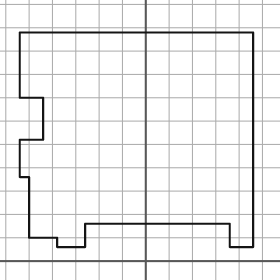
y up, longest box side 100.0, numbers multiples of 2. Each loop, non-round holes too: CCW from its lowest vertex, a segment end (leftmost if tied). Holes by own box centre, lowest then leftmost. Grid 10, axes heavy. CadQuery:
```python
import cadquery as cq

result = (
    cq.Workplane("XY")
    .moveTo(-38.0, 6.0)
    .lineTo(-26.0, 6.0)
    .lineTo(-26.0, 16.0)
    .lineTo(36.0, 16.0)
    .lineTo(36.0, 6.0)
    .lineTo(46.0, 6.0)
    .lineTo(46.0, 98.0)
    .lineTo(-54.0, 98.0)
    .lineTo(-54.0, 70.0)
    .lineTo(-44.0, 70.0)
    .lineTo(-44.0, 52.0)
    .lineTo(-54.0, 52.0)
    .lineTo(-54.0, 36.0)
    .lineTo(-50.0, 36.0)
    .lineTo(-50.0, 10.0)
    .lineTo(-38.0, 10.0)
    .close()
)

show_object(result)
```